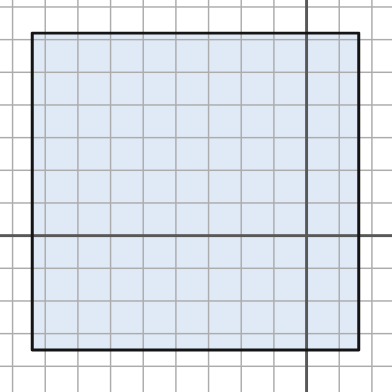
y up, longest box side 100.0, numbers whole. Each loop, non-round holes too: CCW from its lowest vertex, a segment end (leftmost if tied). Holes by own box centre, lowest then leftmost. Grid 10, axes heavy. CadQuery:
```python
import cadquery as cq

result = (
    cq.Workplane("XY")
    .moveTo(-84.0, -35.0)
    .lineTo(16.0, -35.0)
    .lineTo(16.0, 62.0)
    .lineTo(-84.0, 62.0)
    .close()
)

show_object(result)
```